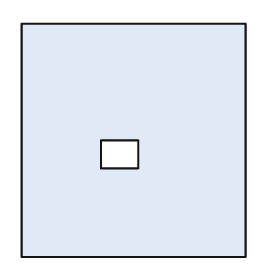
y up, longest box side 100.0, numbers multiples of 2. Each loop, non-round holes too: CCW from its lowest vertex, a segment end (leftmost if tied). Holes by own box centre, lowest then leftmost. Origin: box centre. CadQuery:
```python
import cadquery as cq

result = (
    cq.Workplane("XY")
    .moveTo(-48.0, -50.0)
    .lineTo(48.0, -50.0)
    .lineTo(48.0, 50.0)
    .lineTo(-48.0, 50.0)
    .close()
    .moveTo(-14.0, -12.0)
    .lineTo(2.0, -12.0)
    .lineTo(2.0, 0.0)
    .lineTo(-14.0, 0.0)
    .close()
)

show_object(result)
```